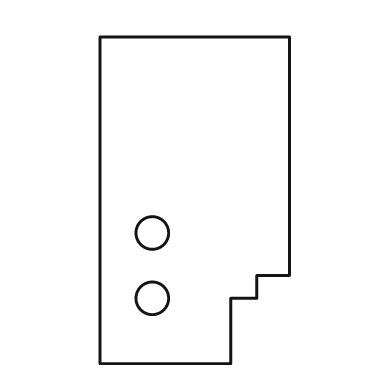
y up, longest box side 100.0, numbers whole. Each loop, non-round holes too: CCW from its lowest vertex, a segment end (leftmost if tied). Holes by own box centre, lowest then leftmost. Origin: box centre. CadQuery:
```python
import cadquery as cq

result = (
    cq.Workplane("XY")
    .moveTo(-29.0, -50.0)
    .lineTo(11.0, -50.0)
    .lineTo(11.0, -30.0)
    .lineTo(19.0, -30.0)
    .lineTo(19.0, -23.0)
    .lineTo(29.0, -23.0)
    .lineTo(29.0, 50.0)
    .lineTo(-29.0, 50.0)
    .close()
    .moveTo(-13.0, -30.0)
    .circle(5.0)
    .moveTo(-13.0, -10.0)
    .circle(5.0)
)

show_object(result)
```